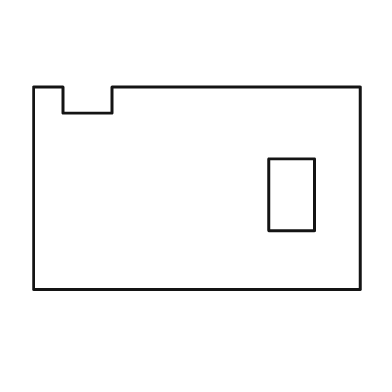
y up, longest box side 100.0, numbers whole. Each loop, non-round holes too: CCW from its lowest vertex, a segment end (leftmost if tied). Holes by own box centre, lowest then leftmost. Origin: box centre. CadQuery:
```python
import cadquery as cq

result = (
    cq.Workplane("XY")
    .moveTo(-50.0, -31.0)
    .lineTo(50.0, -31.0)
    .lineTo(50.0, 31.0)
    .lineTo(-26.0, 31.0)
    .lineTo(-26.0, 23.0)
    .lineTo(-41.0, 23.0)
    .lineTo(-41.0, 31.0)
    .lineTo(-50.0, 31.0)
    .close()
    .moveTo(22.0, -13.0)
    .lineTo(36.0, -13.0)
    .lineTo(36.0, 9.0)
    .lineTo(22.0, 9.0)
    .close()
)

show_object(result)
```